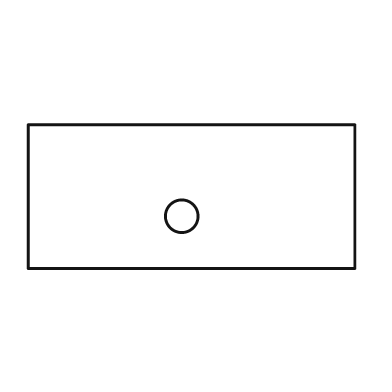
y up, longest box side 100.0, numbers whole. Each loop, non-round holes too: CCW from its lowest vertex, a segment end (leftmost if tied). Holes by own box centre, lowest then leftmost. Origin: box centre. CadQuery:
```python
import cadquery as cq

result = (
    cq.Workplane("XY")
    .moveTo(-50.0, -22.0)
    .lineTo(50.0, -22.0)
    .lineTo(50.0, 22.0)
    .lineTo(-50.0, 22.0)
    .close()
    .moveTo(-3.0, -6.0)
    .circle(5.0)
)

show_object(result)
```